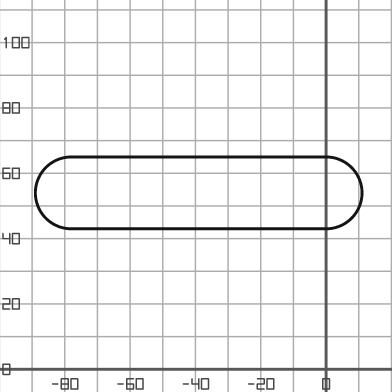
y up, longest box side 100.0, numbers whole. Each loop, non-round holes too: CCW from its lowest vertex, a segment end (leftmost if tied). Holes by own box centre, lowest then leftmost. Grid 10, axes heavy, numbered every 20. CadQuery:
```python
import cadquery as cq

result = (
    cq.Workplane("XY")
    .moveTo(-78.0, 43.0)
    .lineTo(0.0, 43.0)
    .threePointArc((11.0, 54.0), (0.0, 65.0))
    .lineTo(-78.0, 65.0)
    .threePointArc((-89.0, 54.0), (-78.0, 43.0))
    .close()
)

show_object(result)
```